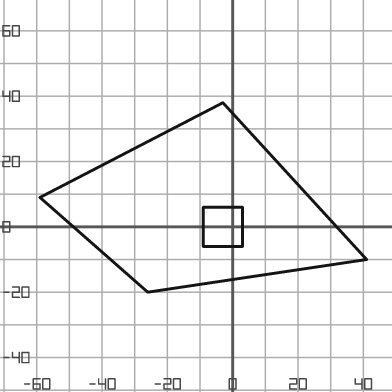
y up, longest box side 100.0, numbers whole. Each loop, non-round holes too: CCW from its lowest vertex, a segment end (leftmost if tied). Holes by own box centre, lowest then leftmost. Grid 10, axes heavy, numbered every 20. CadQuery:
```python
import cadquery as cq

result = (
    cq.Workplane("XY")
    .moveTo(-26.0, -20.0)
    .lineTo(41.0, -10.0)
    .lineTo(-3.0, 38.0)
    .lineTo(-59.0, 9.0)
    .close()
    .moveTo(-9.0, -6.0)
    .lineTo(3.0, -6.0)
    .lineTo(3.0, 6.0)
    .lineTo(-9.0, 6.0)
    .close()
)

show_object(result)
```